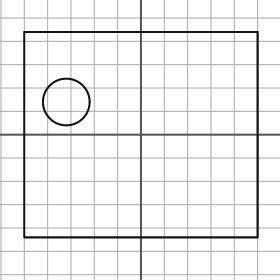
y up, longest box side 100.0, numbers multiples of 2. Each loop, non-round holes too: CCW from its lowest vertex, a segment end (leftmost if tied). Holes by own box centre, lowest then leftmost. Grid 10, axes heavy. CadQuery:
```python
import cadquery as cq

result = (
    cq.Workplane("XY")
    .moveTo(-50.0, -44.0)
    .lineTo(50.0, -44.0)
    .lineTo(50.0, 44.0)
    .lineTo(-50.0, 44.0)
    .close()
    .moveTo(-32.0, 14.0)
    .circle(10.0)
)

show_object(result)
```